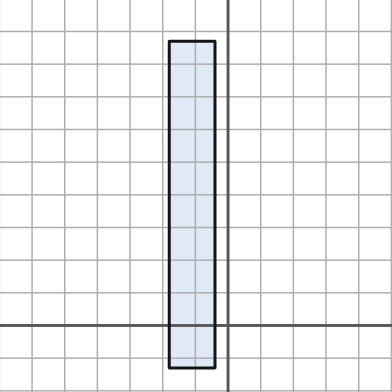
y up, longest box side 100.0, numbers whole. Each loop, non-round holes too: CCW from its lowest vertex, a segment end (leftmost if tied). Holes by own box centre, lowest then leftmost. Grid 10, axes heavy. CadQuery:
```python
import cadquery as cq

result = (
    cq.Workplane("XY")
    .moveTo(-18.0, -13.0)
    .lineTo(-4.0, -13.0)
    .lineTo(-4.0, 87.0)
    .lineTo(-18.0, 87.0)
    .close()
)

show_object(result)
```